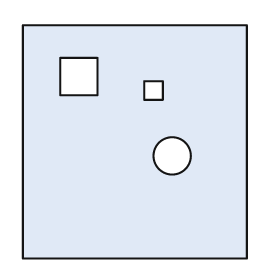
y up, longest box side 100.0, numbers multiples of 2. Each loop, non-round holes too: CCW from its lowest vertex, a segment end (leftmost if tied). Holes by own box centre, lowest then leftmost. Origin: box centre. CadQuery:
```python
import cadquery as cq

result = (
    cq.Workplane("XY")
    .moveTo(-48.0, -50.0)
    .lineTo(48.0, -50.0)
    .lineTo(48.0, 50.0)
    .lineTo(-48.0, 50.0)
    .close()
    .moveTo(16.0, -6.0)
    .circle(8.0)
    .moveTo(4.0, 18.0)
    .lineTo(12.0, 18.0)
    .lineTo(12.0, 26.0)
    .lineTo(4.0, 26.0)
    .close()
    .moveTo(-32.0, 20.0)
    .lineTo(-16.0, 20.0)
    .lineTo(-16.0, 36.0)
    .lineTo(-32.0, 36.0)
    .close()
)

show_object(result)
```